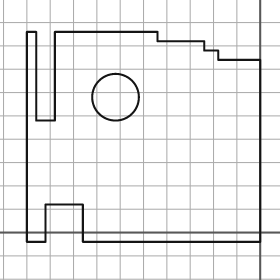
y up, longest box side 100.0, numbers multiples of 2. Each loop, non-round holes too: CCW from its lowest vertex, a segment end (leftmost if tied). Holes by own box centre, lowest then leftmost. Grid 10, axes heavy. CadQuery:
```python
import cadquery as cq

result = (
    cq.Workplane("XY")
    .moveTo(-100.0, -4.0)
    .lineTo(-92.0, -4.0)
    .lineTo(-92.0, 12.0)
    .lineTo(-76.0, 12.0)
    .lineTo(-76.0, -4.0)
    .lineTo(0.0, -4.0)
    .lineTo(0.0, 74.0)
    .lineTo(-18.0, 74.0)
    .lineTo(-18.0, 78.0)
    .lineTo(-24.0, 78.0)
    .lineTo(-24.0, 82.0)
    .lineTo(-44.0, 82.0)
    .lineTo(-44.0, 86.0)
    .lineTo(-88.0, 86.0)
    .lineTo(-88.0, 48.0)
    .lineTo(-96.0, 48.0)
    .lineTo(-96.0, 86.0)
    .lineTo(-100.0, 86.0)
    .close()
    .moveTo(-62.0, 58.0)
    .circle(10.0)
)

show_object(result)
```